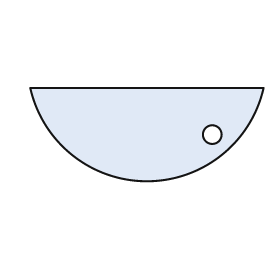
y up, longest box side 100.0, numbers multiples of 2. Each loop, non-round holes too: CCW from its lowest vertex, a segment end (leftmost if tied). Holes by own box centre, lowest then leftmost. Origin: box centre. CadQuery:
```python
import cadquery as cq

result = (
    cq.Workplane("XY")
    .moveTo(-50.0, 20.0)
    .threePointArc((0.0, -20.0), (50.0, 20.0))
    .close()
    .moveTo(28.0, 0.0)
    .circle(4.0)
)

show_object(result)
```